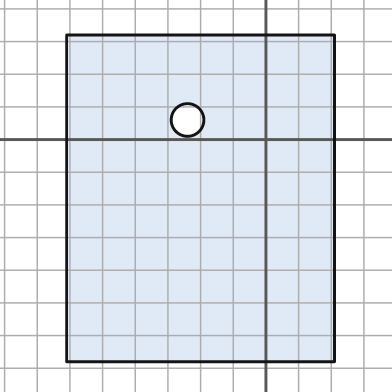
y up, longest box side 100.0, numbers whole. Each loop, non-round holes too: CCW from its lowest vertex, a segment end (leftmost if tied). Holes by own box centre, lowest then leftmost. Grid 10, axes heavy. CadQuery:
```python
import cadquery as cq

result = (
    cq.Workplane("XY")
    .moveTo(-61.0, -68.0)
    .lineTo(21.0, -68.0)
    .lineTo(21.0, 32.0)
    .lineTo(-61.0, 32.0)
    .close()
    .moveTo(-24.0, 6.0)
    .circle(5.0)
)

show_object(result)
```